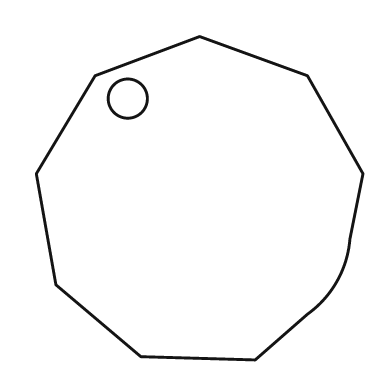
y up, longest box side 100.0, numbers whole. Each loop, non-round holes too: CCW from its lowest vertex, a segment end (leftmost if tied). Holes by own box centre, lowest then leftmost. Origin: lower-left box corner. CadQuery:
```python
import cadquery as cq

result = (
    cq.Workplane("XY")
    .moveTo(67.0, 0.0)
    .lineTo(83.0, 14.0)
    .threePointArc((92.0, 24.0), (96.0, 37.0))
    .lineTo(100.0, 57.0)
    .lineTo(83.0, 87.0)
    .lineTo(50.0, 99.0)
    .lineTo(18.0, 87.0)
    .lineTo(0.0, 57.0)
    .lineTo(6.0, 23.0)
    .lineTo(32.0, 1.0)
    .close()
    .moveTo(28.0, 80.0)
    .circle(6.0)
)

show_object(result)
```